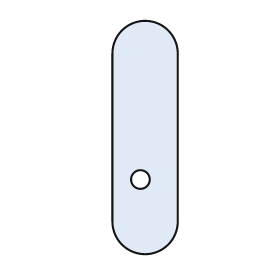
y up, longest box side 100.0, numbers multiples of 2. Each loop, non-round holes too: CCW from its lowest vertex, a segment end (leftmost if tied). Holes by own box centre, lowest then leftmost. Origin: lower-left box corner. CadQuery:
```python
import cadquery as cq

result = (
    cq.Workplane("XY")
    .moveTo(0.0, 14.0)
    .threePointArc((14.0, 0.0), (28.0, 14.0))
    .lineTo(28.0, 86.0)
    .threePointArc((14.0, 100.0), (0.0, 86.0))
    .close()
    .moveTo(12.0, 32.0)
    .circle(4.0)
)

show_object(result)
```